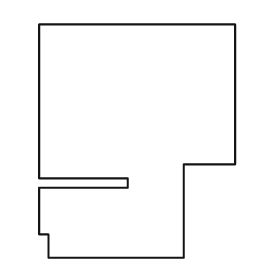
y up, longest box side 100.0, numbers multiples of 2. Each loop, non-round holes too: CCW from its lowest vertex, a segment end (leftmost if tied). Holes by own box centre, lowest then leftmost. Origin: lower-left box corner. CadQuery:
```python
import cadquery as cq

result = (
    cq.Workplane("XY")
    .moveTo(4.0, 0.0)
    .lineTo(62.0, 0.0)
    .lineTo(62.0, 40.0)
    .lineTo(84.0, 40.0)
    .lineTo(84.0, 100.0)
    .lineTo(0.0, 100.0)
    .lineTo(0.0, 34.0)
    .lineTo(38.0, 34.0)
    .lineTo(38.0, 30.0)
    .lineTo(0.0, 30.0)
    .lineTo(0.0, 10.0)
    .lineTo(4.0, 10.0)
    .close()
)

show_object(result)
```